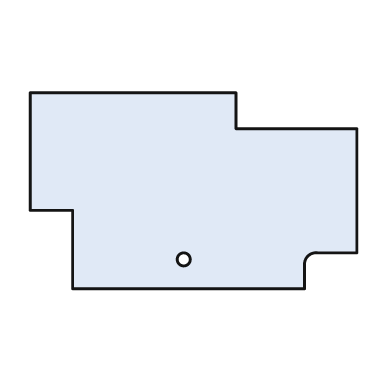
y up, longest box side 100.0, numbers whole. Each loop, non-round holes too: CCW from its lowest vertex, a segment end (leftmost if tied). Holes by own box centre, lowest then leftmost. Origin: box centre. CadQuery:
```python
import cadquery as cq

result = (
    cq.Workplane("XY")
    .moveTo(-37.0, -30.0)
    .lineTo(34.0, -30.0)
    .lineTo(34.0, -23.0)
    .threePointArc((35.0, -20.0), (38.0, -19.0))
    .lineTo(50.0, -19.0)
    .lineTo(50.0, 19.0)
    .lineTo(13.0, 19.0)
    .lineTo(13.0, 30.0)
    .lineTo(-50.0, 30.0)
    .lineTo(-50.0, -6.0)
    .lineTo(-37.0, -6.0)
    .close()
    .moveTo(-3.0, -21.0)
    .circle(2.0)
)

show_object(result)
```